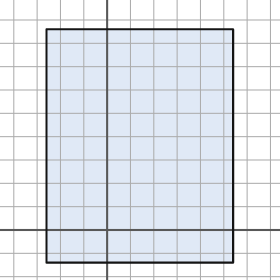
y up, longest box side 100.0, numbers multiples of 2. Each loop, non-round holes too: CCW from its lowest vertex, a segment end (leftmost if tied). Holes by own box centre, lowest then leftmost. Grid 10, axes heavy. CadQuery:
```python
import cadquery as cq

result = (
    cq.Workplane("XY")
    .moveTo(-26.0, -14.0)
    .lineTo(54.0, -14.0)
    .lineTo(54.0, 86.0)
    .lineTo(-26.0, 86.0)
    .close()
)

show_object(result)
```